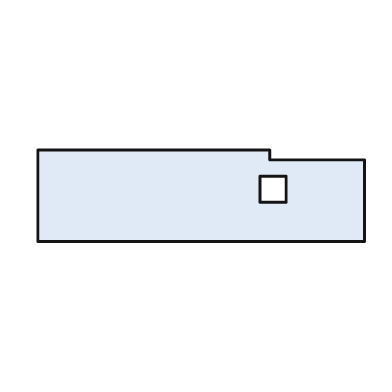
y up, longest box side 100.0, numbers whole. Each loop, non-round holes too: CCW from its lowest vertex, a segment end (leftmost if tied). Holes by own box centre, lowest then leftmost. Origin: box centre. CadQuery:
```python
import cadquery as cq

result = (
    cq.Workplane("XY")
    .moveTo(-50.0, -14.0)
    .lineTo(50.0, -14.0)
    .lineTo(50.0, 11.0)
    .lineTo(21.0, 11.0)
    .lineTo(21.0, 14.0)
    .lineTo(-50.0, 14.0)
    .close()
    .moveTo(18.0, -2.0)
    .lineTo(26.0, -2.0)
    .lineTo(26.0, 6.0)
    .lineTo(18.0, 6.0)
    .close()
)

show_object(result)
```